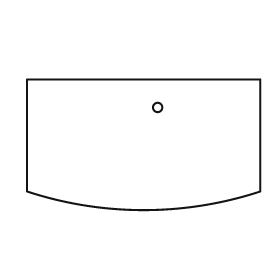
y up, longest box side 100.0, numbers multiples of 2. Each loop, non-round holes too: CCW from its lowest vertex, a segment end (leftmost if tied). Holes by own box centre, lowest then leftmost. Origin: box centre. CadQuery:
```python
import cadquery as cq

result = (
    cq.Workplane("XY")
    .moveTo(-50.0, -20.0)
    .threePointArc((0.0, -28.0), (50.0, -20.0))
    .lineTo(50.0, 28.0)
    .lineTo(-50.0, 28.0)
    .close()
    .moveTo(6.0, 16.0)
    .circle(2.0)
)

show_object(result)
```